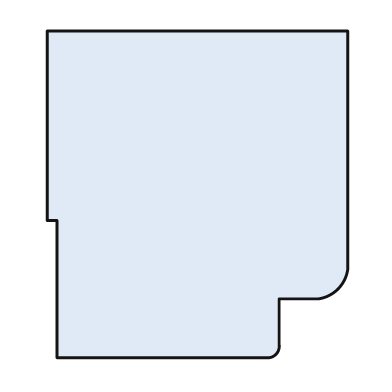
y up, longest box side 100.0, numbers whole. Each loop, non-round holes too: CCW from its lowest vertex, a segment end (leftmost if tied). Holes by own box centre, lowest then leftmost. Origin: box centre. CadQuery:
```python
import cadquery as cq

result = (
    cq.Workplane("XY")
    .moveTo(-43.0, -50.0)
    .lineTo(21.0, -50.0)
    .threePointArc((24.0, -49.0), (25.0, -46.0))
    .lineTo(25.0, -32.0)
    .lineTo(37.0, -32.0)
    .threePointArc((43.0, -29.0), (46.0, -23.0))
    .lineTo(46.0, 50.0)
    .lineTo(-46.0, 50.0)
    .lineTo(-46.0, -8.0)
    .lineTo(-43.0, -8.0)
    .close()
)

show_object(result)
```